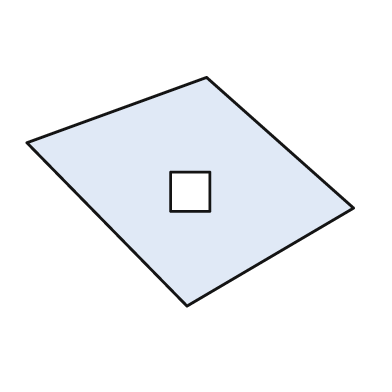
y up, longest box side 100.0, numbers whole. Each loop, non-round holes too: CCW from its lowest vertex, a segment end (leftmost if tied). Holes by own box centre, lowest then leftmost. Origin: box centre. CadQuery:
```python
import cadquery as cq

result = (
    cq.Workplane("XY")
    .moveTo(-1.0, -35.0)
    .lineTo(50.0, -5.0)
    .lineTo(5.0, 35.0)
    .lineTo(-50.0, 15.0)
    .close()
    .moveTo(-6.0, -6.0)
    .lineTo(6.0, -6.0)
    .lineTo(6.0, 6.0)
    .lineTo(-6.0, 6.0)
    .close()
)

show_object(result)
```